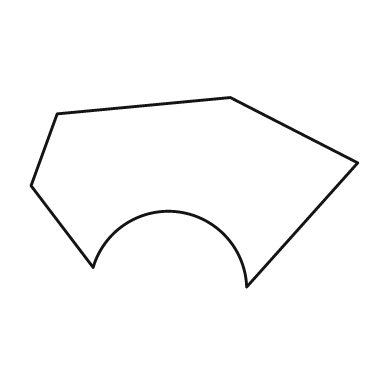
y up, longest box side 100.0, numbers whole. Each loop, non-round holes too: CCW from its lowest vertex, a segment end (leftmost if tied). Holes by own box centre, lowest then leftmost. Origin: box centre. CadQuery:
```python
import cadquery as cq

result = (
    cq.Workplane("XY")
    .moveTo(16.0, -29.0)
    .lineTo(50.0, 9.0)
    .lineTo(11.0, 29.0)
    .lineTo(-42.0, 24.0)
    .lineTo(-50.0, 2.0)
    .lineTo(-31.0, -23.0)
    .threePointArc((-5.0, -6.0), (16.0, -29.0))
    .close()
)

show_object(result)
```